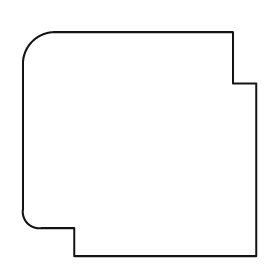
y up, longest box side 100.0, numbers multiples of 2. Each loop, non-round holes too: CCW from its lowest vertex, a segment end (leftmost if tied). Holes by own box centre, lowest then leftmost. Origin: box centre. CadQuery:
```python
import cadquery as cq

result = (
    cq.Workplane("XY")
    .moveTo(-28.0, -48.0)
    .lineTo(50.0, -48.0)
    .lineTo(50.0, 26.0)
    .lineTo(40.0, 26.0)
    .lineTo(40.0, 48.0)
    .lineTo(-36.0, 48.0)
    .threePointArc((-46.0, 44.0), (-50.0, 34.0))
    .lineTo(-50.0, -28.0)
    .threePointArc((-48.0, -34.0), (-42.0, -36.0))
    .lineTo(-28.0, -36.0)
    .close()
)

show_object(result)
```